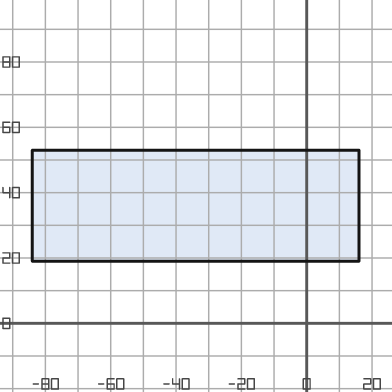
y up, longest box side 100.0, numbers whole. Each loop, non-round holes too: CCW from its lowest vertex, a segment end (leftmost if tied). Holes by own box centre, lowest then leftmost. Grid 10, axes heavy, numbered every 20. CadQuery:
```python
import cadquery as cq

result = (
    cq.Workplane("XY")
    .moveTo(-84.0, 19.0)
    .lineTo(16.0, 19.0)
    .lineTo(16.0, 53.0)
    .lineTo(-84.0, 53.0)
    .close()
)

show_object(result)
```